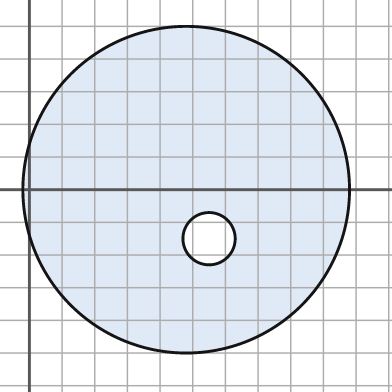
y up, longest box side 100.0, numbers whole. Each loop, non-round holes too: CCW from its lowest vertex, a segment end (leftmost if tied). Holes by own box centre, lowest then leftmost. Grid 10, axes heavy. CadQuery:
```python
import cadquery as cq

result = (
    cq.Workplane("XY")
    .moveTo(48.0, 0.0)
    .circle(50.0)
    .moveTo(55.0, -15.0)
    .circle(8.0)
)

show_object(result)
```